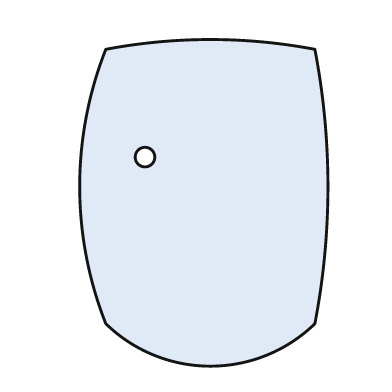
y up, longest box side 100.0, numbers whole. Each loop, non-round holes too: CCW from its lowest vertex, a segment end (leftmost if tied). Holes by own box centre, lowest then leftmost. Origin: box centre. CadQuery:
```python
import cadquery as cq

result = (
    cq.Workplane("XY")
    .moveTo(-30.0, -37.0)
    .threePointArc((2.0, -50.0), (34.0, -37.0))
    .threePointArc((38.0, 5.0), (34.0, 47.0))
    .threePointArc((2.0, 50.0), (-30.0, 47.0))
    .threePointArc((-38.0, 5.0), (-30.0, -37.0))
    .close()
    .moveTo(-18.0, 14.0)
    .circle(3.0)
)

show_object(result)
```